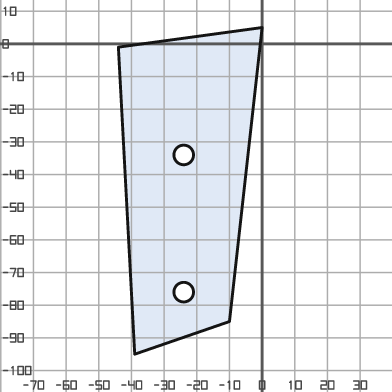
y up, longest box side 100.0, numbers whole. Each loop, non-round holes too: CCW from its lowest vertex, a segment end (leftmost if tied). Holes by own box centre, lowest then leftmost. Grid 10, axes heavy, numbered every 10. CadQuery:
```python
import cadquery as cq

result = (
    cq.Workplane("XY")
    .moveTo(-39.0, -95.0)
    .lineTo(-10.0, -85.0)
    .lineTo(0.0, 5.0)
    .lineTo(-44.0, -1.0)
    .close()
    .moveTo(-24.0, -76.0)
    .circle(3.0)
    .moveTo(-24.0, -34.0)
    .circle(3.0)
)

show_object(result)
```